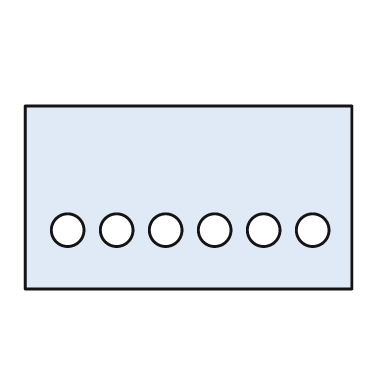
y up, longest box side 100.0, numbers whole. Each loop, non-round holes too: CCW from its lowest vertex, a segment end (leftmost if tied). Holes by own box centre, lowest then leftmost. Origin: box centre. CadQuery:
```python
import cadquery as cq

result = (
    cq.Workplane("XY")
    .moveTo(-50.0, -28.0)
    .lineTo(50.0, -28.0)
    .lineTo(50.0, 28.0)
    .lineTo(-50.0, 28.0)
    .close()
    .moveTo(-37.0, -10.0)
    .circle(5.0)
    .moveTo(-22.0, -10.0)
    .circle(5.0)
    .moveTo(-7.0, -10.0)
    .circle(5.0)
    .moveTo(8.0, -10.0)
    .circle(5.0)
    .moveTo(23.0, -10.0)
    .circle(5.0)
    .moveTo(38.0, -10.0)
    .circle(5.0)
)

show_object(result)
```